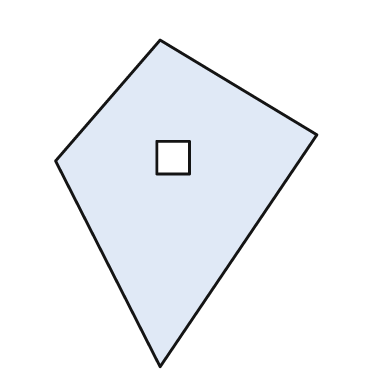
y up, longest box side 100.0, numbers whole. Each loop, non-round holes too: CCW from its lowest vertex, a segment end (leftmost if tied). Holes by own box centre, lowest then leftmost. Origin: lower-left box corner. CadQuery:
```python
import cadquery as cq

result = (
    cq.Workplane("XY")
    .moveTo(32.0, 0.0)
    .lineTo(80.0, 71.0)
    .lineTo(32.0, 100.0)
    .lineTo(0.0, 63.0)
    .close()
    .moveTo(31.0, 59.0)
    .lineTo(41.0, 59.0)
    .lineTo(41.0, 69.0)
    .lineTo(31.0, 69.0)
    .close()
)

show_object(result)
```